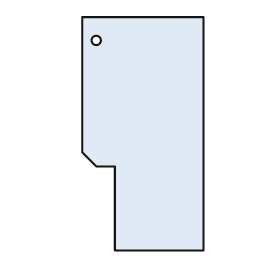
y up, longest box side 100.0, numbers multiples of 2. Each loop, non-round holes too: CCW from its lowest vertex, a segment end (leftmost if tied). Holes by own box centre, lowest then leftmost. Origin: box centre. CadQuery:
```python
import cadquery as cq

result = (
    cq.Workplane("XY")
    .moveTo(-12.0, -50.0)
    .lineTo(26.0, -50.0)
    .lineTo(26.0, 50.0)
    .lineTo(-26.0, 50.0)
    .lineTo(-26.0, -8.0)
    .lineTo(-20.0, -14.0)
    .lineTo(-12.0, -14.0)
    .close()
    .moveTo(-20.0, 40.0)
    .circle(2.0)
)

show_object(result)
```